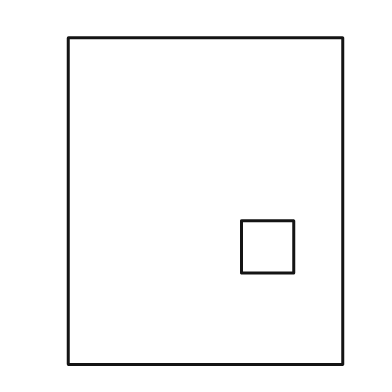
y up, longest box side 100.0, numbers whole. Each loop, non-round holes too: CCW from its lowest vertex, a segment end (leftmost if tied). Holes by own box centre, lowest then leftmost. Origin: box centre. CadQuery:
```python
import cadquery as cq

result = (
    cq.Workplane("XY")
    .moveTo(-42.0, -50.0)
    .lineTo(42.0, -50.0)
    .lineTo(42.0, 50.0)
    .lineTo(-42.0, 50.0)
    .close()
    .moveTo(11.0, -22.0)
    .lineTo(27.0, -22.0)
    .lineTo(27.0, -6.0)
    .lineTo(11.0, -6.0)
    .close()
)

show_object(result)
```